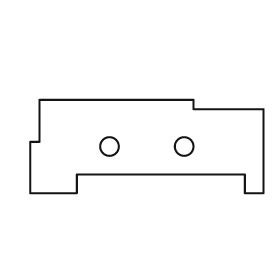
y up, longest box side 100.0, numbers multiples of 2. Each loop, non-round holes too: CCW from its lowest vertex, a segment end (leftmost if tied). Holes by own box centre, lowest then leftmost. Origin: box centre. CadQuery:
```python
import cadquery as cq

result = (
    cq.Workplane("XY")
    .moveTo(-50.0, -20.0)
    .lineTo(-30.0, -20.0)
    .lineTo(-30.0, -12.0)
    .lineTo(42.0, -12.0)
    .lineTo(42.0, -20.0)
    .lineTo(50.0, -20.0)
    .lineTo(50.0, 16.0)
    .lineTo(20.0, 16.0)
    .lineTo(20.0, 20.0)
    .lineTo(-46.0, 20.0)
    .lineTo(-46.0, 2.0)
    .lineTo(-50.0, 2.0)
    .close()
    .moveTo(-16.0, 0.0)
    .circle(4.0)
    .moveTo(16.0, 0.0)
    .circle(4.0)
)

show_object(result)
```